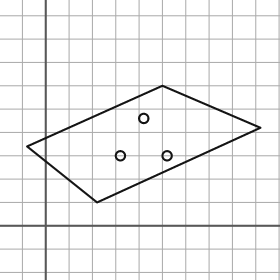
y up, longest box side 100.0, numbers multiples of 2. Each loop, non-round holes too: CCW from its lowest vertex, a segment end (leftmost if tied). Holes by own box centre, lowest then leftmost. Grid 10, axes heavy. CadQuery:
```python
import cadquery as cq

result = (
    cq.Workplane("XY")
    .moveTo(22.0, 10.0)
    .lineTo(92.0, 42.0)
    .lineTo(50.0, 60.0)
    .lineTo(-8.0, 34.0)
    .close()
    .moveTo(32.0, 30.0)
    .circle(2.0)
    .moveTo(52.0, 30.0)
    .circle(2.0)
    .moveTo(42.0, 46.0)
    .circle(2.0)
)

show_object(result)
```